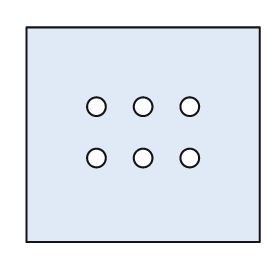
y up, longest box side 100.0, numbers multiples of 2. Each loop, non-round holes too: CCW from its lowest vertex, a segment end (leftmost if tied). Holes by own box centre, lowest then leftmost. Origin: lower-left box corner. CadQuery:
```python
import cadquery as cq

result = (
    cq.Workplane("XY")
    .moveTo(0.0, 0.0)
    .lineTo(100.0, 0.0)
    .lineTo(100.0, 92.0)
    .lineTo(0.0, 92.0)
    .close()
    .moveTo(30.0, 36.0)
    .circle(4.0)
    .moveTo(50.0, 36.0)
    .circle(4.0)
    .moveTo(70.0, 36.0)
    .circle(4.0)
    .moveTo(30.0, 58.0)
    .circle(4.0)
    .moveTo(50.0, 58.0)
    .circle(4.0)
    .moveTo(70.0, 58.0)
    .circle(4.0)
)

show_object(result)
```